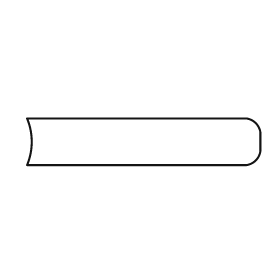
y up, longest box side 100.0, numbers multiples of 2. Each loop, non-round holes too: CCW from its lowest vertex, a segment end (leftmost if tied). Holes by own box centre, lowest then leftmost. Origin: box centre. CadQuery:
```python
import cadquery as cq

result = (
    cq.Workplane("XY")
    .moveTo(-50.0, -10.0)
    .lineTo(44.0, -10.0)
    .threePointArc((48.0, -8.0), (50.0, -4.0))
    .lineTo(50.0, 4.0)
    .threePointArc((48.0, 8.0), (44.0, 10.0))
    .lineTo(-50.0, 10.0)
    .threePointArc((-48.0, 0.0), (-50.0, -10.0))
    .close()
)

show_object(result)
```